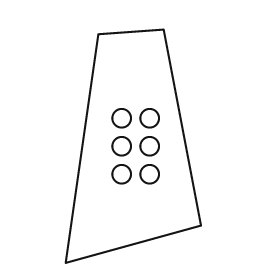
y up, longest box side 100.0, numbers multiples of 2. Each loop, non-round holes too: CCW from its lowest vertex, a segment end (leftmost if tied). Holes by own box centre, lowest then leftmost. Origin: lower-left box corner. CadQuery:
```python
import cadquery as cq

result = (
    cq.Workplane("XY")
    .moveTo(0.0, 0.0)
    .lineTo(58.0, 16.0)
    .lineTo(42.0, 100.0)
    .lineTo(14.0, 98.0)
    .close()
    .moveTo(24.0, 38.0)
    .circle(4.0)
    .moveTo(36.0, 38.0)
    .circle(4.0)
    .moveTo(24.0, 50.0)
    .circle(4.0)
    .moveTo(36.0, 50.0)
    .circle(4.0)
    .moveTo(24.0, 62.0)
    .circle(4.0)
    .moveTo(36.0, 62.0)
    .circle(4.0)
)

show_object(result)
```